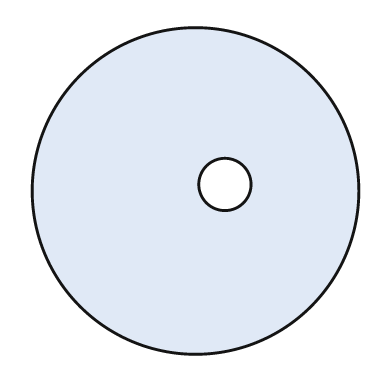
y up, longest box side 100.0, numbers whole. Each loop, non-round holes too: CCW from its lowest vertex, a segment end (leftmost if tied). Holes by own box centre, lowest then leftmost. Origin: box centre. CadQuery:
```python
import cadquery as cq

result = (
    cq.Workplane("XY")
    .moveTo(0.0, 0.0)
    .circle(50.0)
    .moveTo(9.0, 2.0)
    .circle(8.0)
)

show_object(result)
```